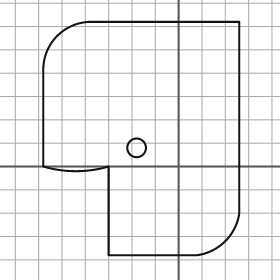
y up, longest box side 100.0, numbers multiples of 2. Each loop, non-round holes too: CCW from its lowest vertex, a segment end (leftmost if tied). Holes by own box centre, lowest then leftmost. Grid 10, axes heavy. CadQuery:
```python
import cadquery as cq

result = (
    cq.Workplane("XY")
    .moveTo(-30.0, -38.0)
    .lineTo(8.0, -38.0)
    .threePointArc((20.0, -32.0), (26.0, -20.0))
    .lineTo(26.0, 62.0)
    .lineTo(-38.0, 62.0)
    .threePointArc((-52.0, 56.0), (-58.0, 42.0))
    .lineTo(-58.0, 0.0)
    .threePointArc((-44.0, -2.0), (-30.0, 0.0))
    .close()
    .moveTo(-18.0, 8.0)
    .circle(4.0)
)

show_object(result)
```